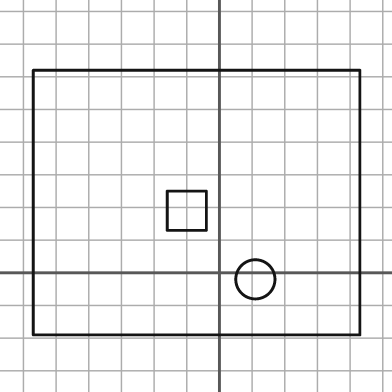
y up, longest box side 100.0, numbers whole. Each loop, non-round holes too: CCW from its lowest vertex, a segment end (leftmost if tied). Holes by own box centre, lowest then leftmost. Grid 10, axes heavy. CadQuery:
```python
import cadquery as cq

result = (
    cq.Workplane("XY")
    .moveTo(-57.0, -19.0)
    .lineTo(43.0, -19.0)
    .lineTo(43.0, 62.0)
    .lineTo(-57.0, 62.0)
    .close()
    .moveTo(11.0, -2.0)
    .circle(6.0)
    .moveTo(-16.0, 13.0)
    .lineTo(-4.0, 13.0)
    .lineTo(-4.0, 25.0)
    .lineTo(-16.0, 25.0)
    .close()
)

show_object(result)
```